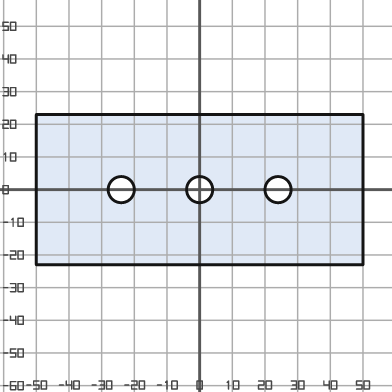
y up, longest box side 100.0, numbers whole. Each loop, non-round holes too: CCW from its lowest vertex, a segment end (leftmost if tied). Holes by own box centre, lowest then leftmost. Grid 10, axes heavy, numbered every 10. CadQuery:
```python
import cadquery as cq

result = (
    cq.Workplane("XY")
    .moveTo(-50.0, -23.0)
    .lineTo(50.0, -23.0)
    .lineTo(50.0, 23.0)
    .lineTo(-50.0, 23.0)
    .close()
    .moveTo(-24.0, 0.0)
    .circle(4.0)
    .moveTo(0.0, 0.0)
    .circle(4.0)
    .moveTo(24.0, 0.0)
    .circle(4.0)
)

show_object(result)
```